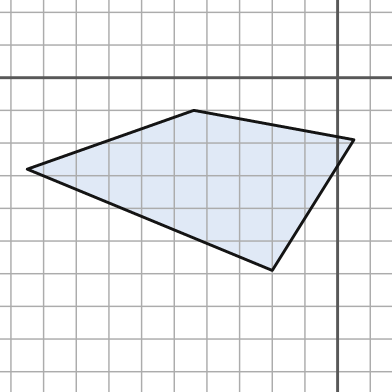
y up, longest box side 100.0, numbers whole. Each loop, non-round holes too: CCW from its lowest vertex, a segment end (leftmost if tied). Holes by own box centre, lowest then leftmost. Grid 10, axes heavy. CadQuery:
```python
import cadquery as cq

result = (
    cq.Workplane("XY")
    .moveTo(-20.0, -59.0)
    .lineTo(5.0, -19.0)
    .lineTo(-44.0, -10.0)
    .lineTo(-95.0, -28.0)
    .close()
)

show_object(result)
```